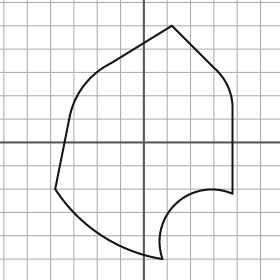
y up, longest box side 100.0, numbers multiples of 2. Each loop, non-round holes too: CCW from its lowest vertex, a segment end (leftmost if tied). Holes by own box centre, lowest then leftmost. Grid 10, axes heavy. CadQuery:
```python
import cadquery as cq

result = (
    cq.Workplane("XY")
    .moveTo(8.0, -50.0)
    .threePointArc((14.0, -26.0), (38.0, -22.0))
    .lineTo(38.0, 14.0)
    .threePointArc((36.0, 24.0), (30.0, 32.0))
    .lineTo(12.0, 50.0)
    .lineTo(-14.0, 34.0)
    .threePointArc((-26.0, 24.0), (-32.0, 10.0))
    .lineTo(-38.0, -20.0)
    .threePointArc((-18.0, -40.0), (8.0, -50.0))
    .close()
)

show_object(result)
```